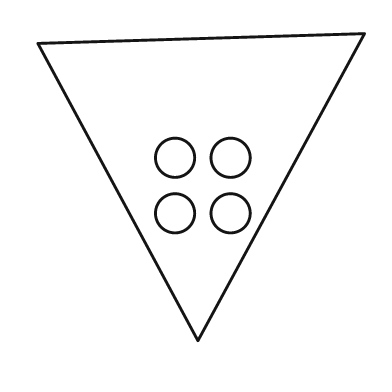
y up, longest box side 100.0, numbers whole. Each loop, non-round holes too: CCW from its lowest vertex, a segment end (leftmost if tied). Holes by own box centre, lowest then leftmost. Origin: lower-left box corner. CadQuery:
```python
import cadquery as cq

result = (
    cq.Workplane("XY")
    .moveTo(49.0, 0.0)
    .lineTo(100.0, 94.0)
    .lineTo(0.0, 91.0)
    .close()
    .moveTo(42.0, 39.0)
    .circle(6.0)
    .moveTo(59.0, 39.0)
    .circle(6.0)
    .moveTo(42.0, 56.0)
    .circle(6.0)
    .moveTo(59.0, 56.0)
    .circle(6.0)
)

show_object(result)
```